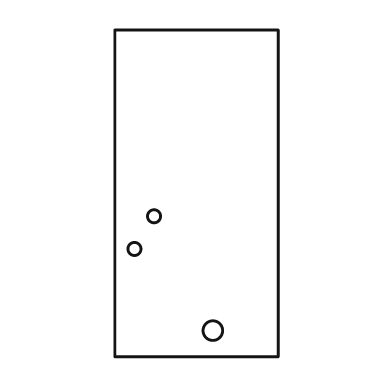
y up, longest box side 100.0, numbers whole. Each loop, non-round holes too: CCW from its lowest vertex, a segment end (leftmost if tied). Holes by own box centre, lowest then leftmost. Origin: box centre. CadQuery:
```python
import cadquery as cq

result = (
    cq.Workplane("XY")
    .moveTo(-25.0, -50.0)
    .lineTo(25.0, -50.0)
    .lineTo(25.0, 50.0)
    .lineTo(-25.0, 50.0)
    .close()
    .moveTo(5.0, -42.0)
    .circle(3.0)
    .moveTo(-19.0, -17.0)
    .circle(2.0)
    .moveTo(-13.0, -7.0)
    .circle(2.0)
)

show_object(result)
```